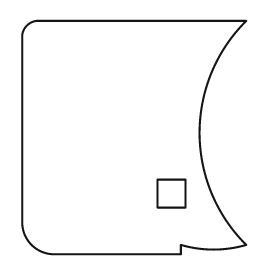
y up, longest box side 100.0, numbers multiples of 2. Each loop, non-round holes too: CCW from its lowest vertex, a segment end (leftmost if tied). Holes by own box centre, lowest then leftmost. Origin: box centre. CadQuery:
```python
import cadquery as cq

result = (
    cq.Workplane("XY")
    .moveTo(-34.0, -50.0)
    .lineTo(20.0, -50.0)
    .lineTo(20.0, -46.0)
    .threePointArc((34.0, -48.0), (48.0, -46.0))
    .threePointArc((28.0, 2.0), (48.0, 50.0))
    .lineTo(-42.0, 50.0)
    .threePointArc((-46.0, 48.0), (-48.0, 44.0))
    .lineTo(-48.0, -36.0)
    .threePointArc((-44.0, -46.0), (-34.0, -50.0))
    .close()
    .moveTo(10.0, -30.0)
    .lineTo(22.0, -30.0)
    .lineTo(22.0, -18.0)
    .lineTo(10.0, -18.0)
    .close()
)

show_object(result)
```